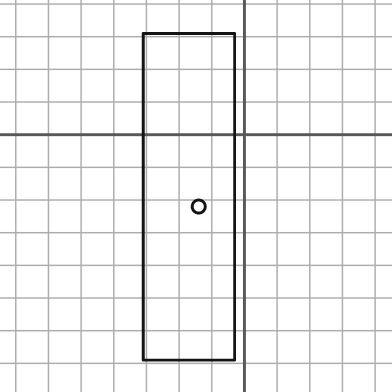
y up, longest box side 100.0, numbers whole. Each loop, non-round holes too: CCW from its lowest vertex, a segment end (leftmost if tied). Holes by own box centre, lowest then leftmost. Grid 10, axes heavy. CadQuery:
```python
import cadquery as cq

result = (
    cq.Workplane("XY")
    .moveTo(-31.0, -69.0)
    .lineTo(-3.0, -69.0)
    .lineTo(-3.0, 31.0)
    .lineTo(-31.0, 31.0)
    .close()
    .moveTo(-14.0, -22.0)
    .circle(2.0)
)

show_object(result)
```